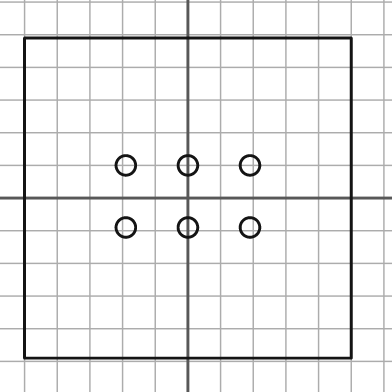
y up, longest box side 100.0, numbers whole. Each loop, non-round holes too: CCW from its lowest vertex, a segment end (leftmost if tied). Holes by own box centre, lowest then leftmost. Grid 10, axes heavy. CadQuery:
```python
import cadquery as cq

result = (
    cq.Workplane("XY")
    .moveTo(-50.0, -49.0)
    .lineTo(50.0, -49.0)
    .lineTo(50.0, 49.0)
    .lineTo(-50.0, 49.0)
    .close()
    .moveTo(-19.0, -9.0)
    .circle(3.0)
    .moveTo(0.0, -9.0)
    .circle(3.0)
    .moveTo(19.0, -9.0)
    .circle(3.0)
    .moveTo(-19.0, 10.0)
    .circle(3.0)
    .moveTo(0.0, 10.0)
    .circle(3.0)
    .moveTo(19.0, 10.0)
    .circle(3.0)
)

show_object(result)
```